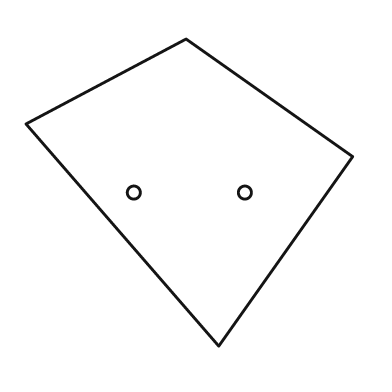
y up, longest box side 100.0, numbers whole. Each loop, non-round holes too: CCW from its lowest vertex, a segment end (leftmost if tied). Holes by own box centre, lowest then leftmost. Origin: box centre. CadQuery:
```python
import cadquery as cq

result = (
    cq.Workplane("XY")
    .moveTo(9.0, -47.0)
    .lineTo(50.0, 11.0)
    .lineTo(-1.0, 47.0)
    .lineTo(-50.0, 21.0)
    .close()
    .moveTo(-17.0, 0.0)
    .circle(2.0)
    .moveTo(17.0, 0.0)
    .circle(2.0)
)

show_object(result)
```